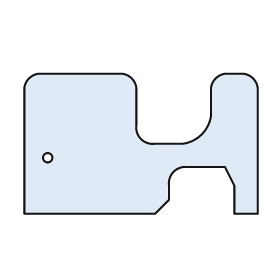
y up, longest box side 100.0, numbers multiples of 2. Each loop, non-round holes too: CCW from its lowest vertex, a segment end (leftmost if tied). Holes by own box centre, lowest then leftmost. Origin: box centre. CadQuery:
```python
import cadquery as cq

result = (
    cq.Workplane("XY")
    .moveTo(-50.0, -30.0)
    .lineTo(6.0, -30.0)
    .lineTo(12.0, -24.0)
    .lineTo(12.0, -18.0)
    .threePointArc((14.0, -12.0), (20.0, -10.0))
    .lineTo(36.0, -10.0)
    .lineTo(40.0, -18.0)
    .lineTo(40.0, -30.0)
    .lineTo(50.0, -30.0)
    .lineTo(50.0, 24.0)
    .threePointArc((48.0, 28.0), (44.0, 30.0))
    .lineTo(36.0, 30.0)
    .threePointArc((32.0, 28.0), (30.0, 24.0))
    .lineTo(30.0, 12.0)
    .threePointArc((26.0, 4.0), (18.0, 0.0))
    .lineTo(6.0, 0.0)
    .threePointArc((0.0, 2.0), (-2.0, 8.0))
    .lineTo(-2.0, 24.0)
    .threePointArc((-4.0, 28.0), (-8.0, 30.0))
    .lineTo(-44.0, 30.0)
    .threePointArc((-48.0, 28.0), (-50.0, 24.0))
    .close()
    .moveTo(-40.0, -6.0)
    .circle(2.0)
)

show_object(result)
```